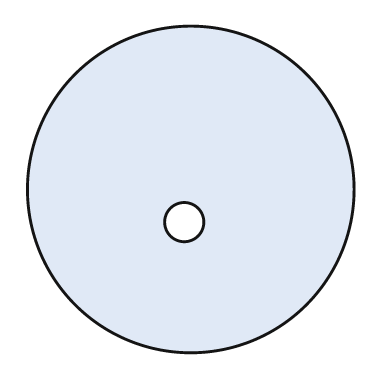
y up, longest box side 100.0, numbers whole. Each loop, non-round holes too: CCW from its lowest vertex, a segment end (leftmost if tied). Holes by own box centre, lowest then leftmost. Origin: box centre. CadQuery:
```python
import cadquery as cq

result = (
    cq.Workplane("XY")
    .moveTo(0.0, 0.0)
    .circle(50.0)
    .moveTo(-2.0, -10.0)
    .circle(6.0)
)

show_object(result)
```